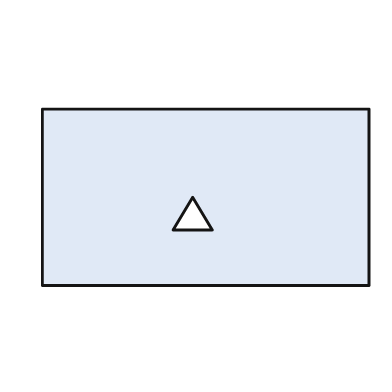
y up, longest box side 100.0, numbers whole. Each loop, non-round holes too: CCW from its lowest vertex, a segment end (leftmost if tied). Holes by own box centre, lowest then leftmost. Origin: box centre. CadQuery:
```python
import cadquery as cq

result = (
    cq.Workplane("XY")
    .moveTo(-50.0, -27.0)
    .lineTo(50.0, -27.0)
    .lineTo(50.0, 27.0)
    .lineTo(-50.0, 27.0)
    .close()
    .moveTo(-10.0, -10.0)
    .lineTo(2.0, -10.0)
    .lineTo(-4.0, 0.0)
    .close()
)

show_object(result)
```